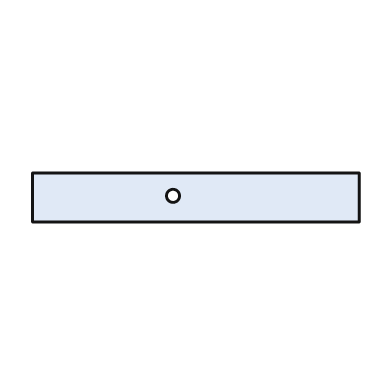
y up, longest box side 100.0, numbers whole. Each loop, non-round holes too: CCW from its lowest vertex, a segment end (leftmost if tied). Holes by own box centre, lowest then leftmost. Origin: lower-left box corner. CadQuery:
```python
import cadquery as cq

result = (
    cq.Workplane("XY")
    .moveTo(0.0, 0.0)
    .lineTo(100.0, 0.0)
    .lineTo(100.0, 15.0)
    .lineTo(0.0, 15.0)
    .close()
    .moveTo(43.0, 8.0)
    .circle(2.0)
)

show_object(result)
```